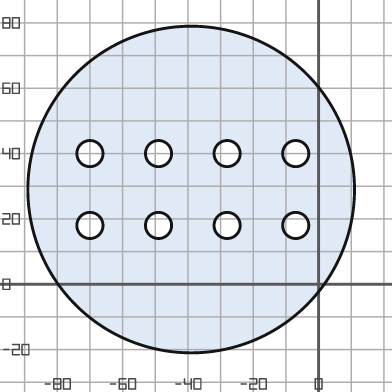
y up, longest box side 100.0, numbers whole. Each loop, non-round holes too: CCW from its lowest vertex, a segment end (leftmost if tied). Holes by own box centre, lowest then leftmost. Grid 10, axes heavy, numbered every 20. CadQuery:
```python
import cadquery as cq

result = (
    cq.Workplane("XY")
    .moveTo(-39.0, 29.0)
    .circle(50.0)
    .moveTo(-70.0, 18.0)
    .circle(4.0)
    .moveTo(-49.0, 18.0)
    .circle(4.0)
    .moveTo(-28.0, 18.0)
    .circle(4.0)
    .moveTo(-7.0, 18.0)
    .circle(4.0)
    .moveTo(-70.0, 40.0)
    .circle(4.0)
    .moveTo(-49.0, 40.0)
    .circle(4.0)
    .moveTo(-28.0, 40.0)
    .circle(4.0)
    .moveTo(-7.0, 40.0)
    .circle(4.0)
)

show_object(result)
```